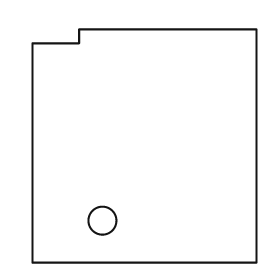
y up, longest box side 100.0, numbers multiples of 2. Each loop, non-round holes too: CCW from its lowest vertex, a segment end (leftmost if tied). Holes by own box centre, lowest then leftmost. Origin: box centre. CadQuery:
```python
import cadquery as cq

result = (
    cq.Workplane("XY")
    .moveTo(-48.0, -50.0)
    .lineTo(48.0, -50.0)
    .lineTo(48.0, 50.0)
    .lineTo(-28.0, 50.0)
    .lineTo(-28.0, 44.0)
    .lineTo(-48.0, 44.0)
    .close()
    .moveTo(-18.0, -32.0)
    .circle(6.0)
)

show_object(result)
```